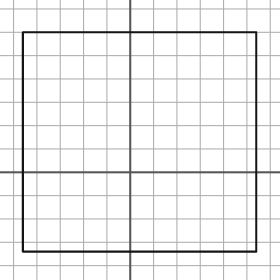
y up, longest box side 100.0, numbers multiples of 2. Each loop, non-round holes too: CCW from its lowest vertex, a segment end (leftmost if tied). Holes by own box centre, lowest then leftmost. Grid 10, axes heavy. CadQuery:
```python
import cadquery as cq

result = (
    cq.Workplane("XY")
    .moveTo(-46.0, -34.0)
    .lineTo(54.0, -34.0)
    .lineTo(54.0, 60.0)
    .lineTo(-46.0, 60.0)
    .close()
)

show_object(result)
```